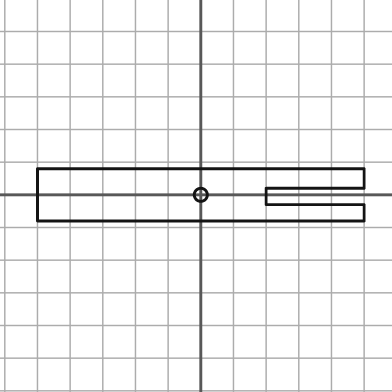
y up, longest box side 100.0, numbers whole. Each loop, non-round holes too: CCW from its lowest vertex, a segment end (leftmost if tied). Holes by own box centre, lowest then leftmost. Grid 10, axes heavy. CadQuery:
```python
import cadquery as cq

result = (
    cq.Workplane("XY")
    .moveTo(-50.0, -8.0)
    .lineTo(50.0, -8.0)
    .lineTo(50.0, -3.0)
    .lineTo(20.0, -3.0)
    .lineTo(20.0, 2.0)
    .lineTo(50.0, 2.0)
    .lineTo(50.0, 8.0)
    .lineTo(-50.0, 8.0)
    .close()
    .moveTo(0.0, 0.0)
    .circle(2.0)
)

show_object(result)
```